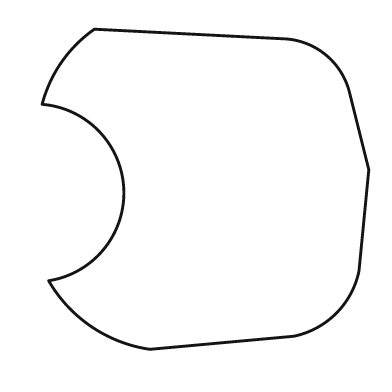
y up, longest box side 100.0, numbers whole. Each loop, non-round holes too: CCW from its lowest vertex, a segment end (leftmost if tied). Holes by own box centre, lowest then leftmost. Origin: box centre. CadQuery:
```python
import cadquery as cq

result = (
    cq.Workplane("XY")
    .moveTo(-17.0, -49.0)
    .lineTo(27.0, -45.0)
    .threePointArc((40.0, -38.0), (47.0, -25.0))
    .lineTo(50.0, 6.0)
    .lineTo(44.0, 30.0)
    .threePointArc((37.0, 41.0), (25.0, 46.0))
    .lineTo(-34.0, 49.0)
    .threePointArc((-44.0, 39.0), (-50.0, 26.0))
    .threePointArc((-25.0, 0.0), (-48.0, -28.0))
    .threePointArc((-35.0, -42.0), (-17.0, -49.0))
    .close()
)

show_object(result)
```